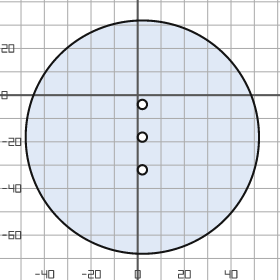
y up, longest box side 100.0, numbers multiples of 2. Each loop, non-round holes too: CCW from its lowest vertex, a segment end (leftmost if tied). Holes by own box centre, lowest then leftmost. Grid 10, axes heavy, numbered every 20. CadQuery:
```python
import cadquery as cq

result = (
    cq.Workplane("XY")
    .moveTo(2.0, -18.0)
    .circle(50.0)
    .moveTo(2.0, -32.0)
    .circle(2.0)
    .moveTo(2.0, -18.0)
    .circle(2.0)
    .moveTo(2.0, -4.0)
    .circle(2.0)
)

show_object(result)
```